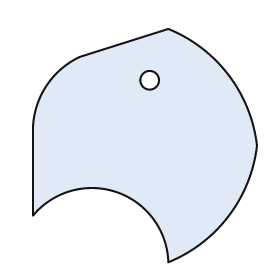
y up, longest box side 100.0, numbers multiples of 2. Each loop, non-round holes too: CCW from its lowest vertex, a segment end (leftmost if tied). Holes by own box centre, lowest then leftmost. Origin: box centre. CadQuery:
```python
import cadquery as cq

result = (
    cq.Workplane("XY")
    .moveTo(10.0, -50.0)
    .threePointArc((36.0, -30.0), (48.0, 0.0))
    .threePointArc((36.0, 30.0), (10.0, 50.0))
    .lineTo(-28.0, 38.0)
    .threePointArc((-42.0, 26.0), (-48.0, 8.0))
    .lineTo(-48.0, -30.0)
    .threePointArc((-12.0, -20.0), (10.0, -50.0))
    .close()
    .moveTo(2.0, 28.0)
    .circle(4.0)
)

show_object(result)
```